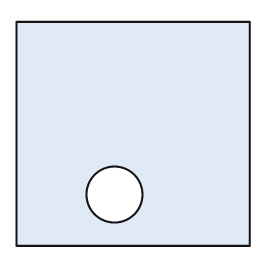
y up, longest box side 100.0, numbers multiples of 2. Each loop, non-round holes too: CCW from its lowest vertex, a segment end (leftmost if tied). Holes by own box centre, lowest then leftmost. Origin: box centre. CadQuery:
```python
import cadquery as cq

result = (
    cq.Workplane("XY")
    .moveTo(-50.0, -48.0)
    .lineTo(50.0, -48.0)
    .lineTo(50.0, 48.0)
    .lineTo(-50.0, 48.0)
    .close()
    .moveTo(-8.0, -26.0)
    .circle(12.0)
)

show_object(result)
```